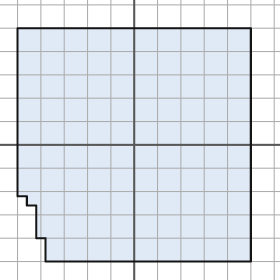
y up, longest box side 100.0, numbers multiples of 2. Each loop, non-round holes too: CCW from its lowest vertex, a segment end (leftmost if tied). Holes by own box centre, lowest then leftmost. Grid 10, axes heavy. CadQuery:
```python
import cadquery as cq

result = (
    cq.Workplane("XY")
    .moveTo(-38.0, -50.0)
    .lineTo(50.0, -50.0)
    .lineTo(50.0, 50.0)
    .lineTo(-50.0, 50.0)
    .lineTo(-50.0, -22.0)
    .lineTo(-46.0, -22.0)
    .lineTo(-46.0, -26.0)
    .lineTo(-42.0, -26.0)
    .lineTo(-42.0, -40.0)
    .lineTo(-38.0, -40.0)
    .close()
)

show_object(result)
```